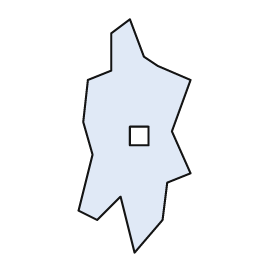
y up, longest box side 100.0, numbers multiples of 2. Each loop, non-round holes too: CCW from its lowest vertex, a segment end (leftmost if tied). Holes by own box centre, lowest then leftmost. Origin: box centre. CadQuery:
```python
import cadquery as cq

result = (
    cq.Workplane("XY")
    .moveTo(0.0, -50.0)
    .lineTo(12.0, -36.0)
    .lineTo(14.0, -20.0)
    .lineTo(24.0, -16.0)
    .lineTo(16.0, 2.0)
    .lineTo(24.0, 24.0)
    .lineTo(10.0, 30.0)
    .lineTo(4.0, 34.0)
    .lineTo(-2.0, 50.0)
    .lineTo(-10.0, 44.0)
    .lineTo(-10.0, 28.0)
    .lineTo(-20.0, 24.0)
    .lineTo(-22.0, 6.0)
    .lineTo(-18.0, -8.0)
    .lineTo(-24.0, -32.0)
    .lineTo(-16.0, -36.0)
    .lineTo(-6.0, -26.0)
    .close()
    .moveTo(-2.0, -4.0)
    .lineTo(6.0, -4.0)
    .lineTo(6.0, 4.0)
    .lineTo(-2.0, 4.0)
    .close()
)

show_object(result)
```